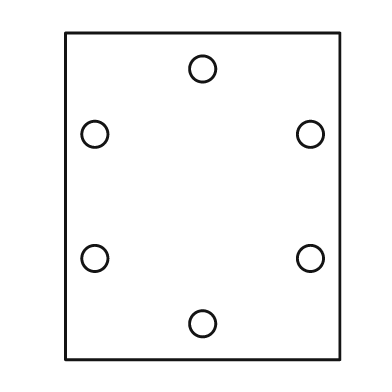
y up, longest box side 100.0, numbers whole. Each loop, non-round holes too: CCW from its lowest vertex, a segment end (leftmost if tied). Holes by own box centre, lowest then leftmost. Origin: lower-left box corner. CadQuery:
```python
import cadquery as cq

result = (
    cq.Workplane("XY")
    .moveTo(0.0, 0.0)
    .lineTo(84.0, 0.0)
    .lineTo(84.0, 100.0)
    .lineTo(0.0, 100.0)
    .close()
    .moveTo(42.0, 11.0)
    .circle(4.0)
    .moveTo(9.0, 31.0)
    .circle(4.0)
    .moveTo(75.0, 31.0)
    .circle(4.0)
    .moveTo(9.0, 69.0)
    .circle(4.0)
    .moveTo(75.0, 69.0)
    .circle(4.0)
    .moveTo(42.0, 89.0)
    .circle(4.0)
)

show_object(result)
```